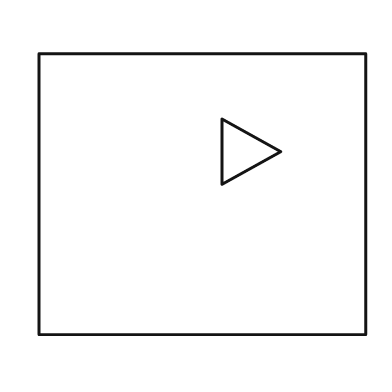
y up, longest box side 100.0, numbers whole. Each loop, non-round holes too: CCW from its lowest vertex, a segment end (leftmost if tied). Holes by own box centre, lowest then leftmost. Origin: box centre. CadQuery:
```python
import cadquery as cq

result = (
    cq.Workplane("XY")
    .moveTo(-50.0, -43.0)
    .lineTo(50.0, -43.0)
    .lineTo(50.0, 43.0)
    .lineTo(-50.0, 43.0)
    .close()
    .moveTo(6.0, 3.0)
    .lineTo(24.0, 13.0)
    .lineTo(6.0, 23.0)
    .close()
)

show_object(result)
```